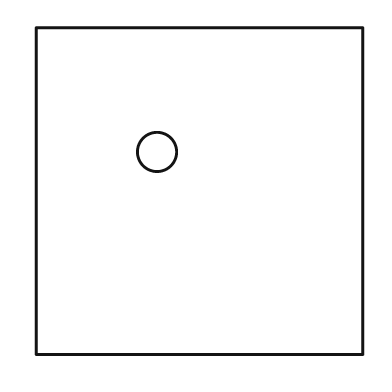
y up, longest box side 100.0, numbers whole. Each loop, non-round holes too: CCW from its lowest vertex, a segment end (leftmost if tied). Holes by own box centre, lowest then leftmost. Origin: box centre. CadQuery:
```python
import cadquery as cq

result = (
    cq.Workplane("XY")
    .moveTo(-50.0, -50.0)
    .lineTo(50.0, -50.0)
    .lineTo(50.0, 50.0)
    .lineTo(-50.0, 50.0)
    .close()
    .moveTo(-13.0, 12.0)
    .circle(6.0)
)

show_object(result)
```